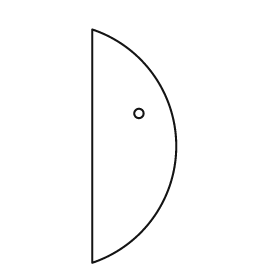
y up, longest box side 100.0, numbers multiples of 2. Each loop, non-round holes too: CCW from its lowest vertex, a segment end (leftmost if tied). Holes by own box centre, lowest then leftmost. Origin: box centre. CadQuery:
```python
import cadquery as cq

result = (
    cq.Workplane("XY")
    .moveTo(-18.0, -50.0)
    .threePointArc((18.0, 0.0), (-18.0, 50.0))
    .close()
    .moveTo(2.0, 14.0)
    .circle(2.0)
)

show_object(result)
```